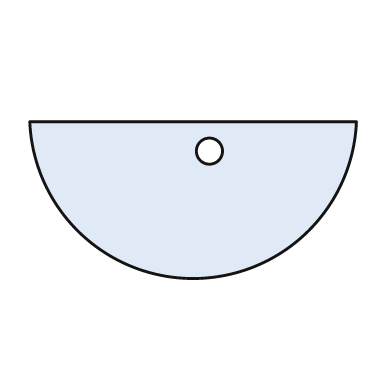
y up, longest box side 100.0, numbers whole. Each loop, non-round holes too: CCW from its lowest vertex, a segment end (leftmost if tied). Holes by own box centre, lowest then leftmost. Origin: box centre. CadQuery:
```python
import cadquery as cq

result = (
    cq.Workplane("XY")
    .moveTo(-50.0, 24.0)
    .threePointArc((0.0, -24.0), (50.0, 24.0))
    .close()
    .moveTo(5.0, 15.0)
    .circle(4.0)
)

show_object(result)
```